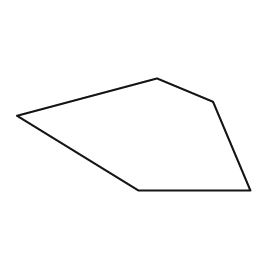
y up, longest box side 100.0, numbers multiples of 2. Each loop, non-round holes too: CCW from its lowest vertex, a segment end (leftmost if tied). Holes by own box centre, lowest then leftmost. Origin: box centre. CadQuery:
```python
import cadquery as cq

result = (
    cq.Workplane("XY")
    .moveTo(2.0, -24.0)
    .lineTo(50.0, -24.0)
    .lineTo(34.0, 14.0)
    .lineTo(10.0, 24.0)
    .lineTo(-50.0, 8.0)
    .close()
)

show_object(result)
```